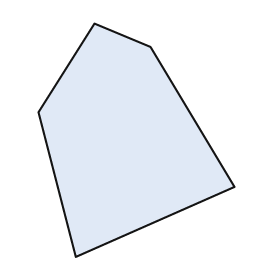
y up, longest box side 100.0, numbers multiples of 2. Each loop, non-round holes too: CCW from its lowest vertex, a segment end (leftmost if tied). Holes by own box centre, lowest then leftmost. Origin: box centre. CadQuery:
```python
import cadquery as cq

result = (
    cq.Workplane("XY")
    .moveTo(-26.0, -50.0)
    .lineTo(42.0, -20.0)
    .lineTo(6.0, 40.0)
    .lineTo(-18.0, 50.0)
    .lineTo(-42.0, 12.0)
    .close()
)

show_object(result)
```